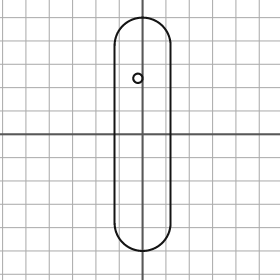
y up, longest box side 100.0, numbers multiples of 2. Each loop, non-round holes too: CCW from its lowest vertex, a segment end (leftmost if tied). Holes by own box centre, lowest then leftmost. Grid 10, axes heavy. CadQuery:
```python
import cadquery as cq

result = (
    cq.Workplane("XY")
    .moveTo(-12.0, -38.0)
    .threePointArc((0.0, -50.0), (12.0, -38.0))
    .lineTo(12.0, 38.0)
    .threePointArc((0.0, 50.0), (-12.0, 38.0))
    .close()
    .moveTo(-2.0, 24.0)
    .circle(2.0)
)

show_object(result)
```